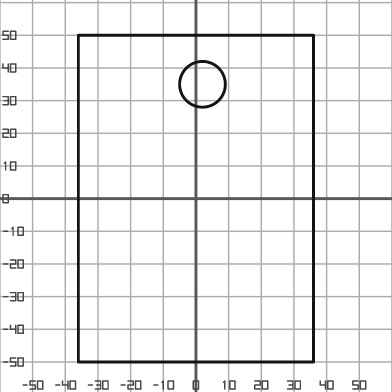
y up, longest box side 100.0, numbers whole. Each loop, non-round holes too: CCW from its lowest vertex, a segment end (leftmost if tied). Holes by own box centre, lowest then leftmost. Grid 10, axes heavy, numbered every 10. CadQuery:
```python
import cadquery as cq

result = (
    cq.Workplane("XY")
    .moveTo(-36.0, -50.0)
    .lineTo(36.0, -50.0)
    .lineTo(36.0, 50.0)
    .lineTo(-36.0, 50.0)
    .close()
    .moveTo(2.0, 35.0)
    .circle(7.0)
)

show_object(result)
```